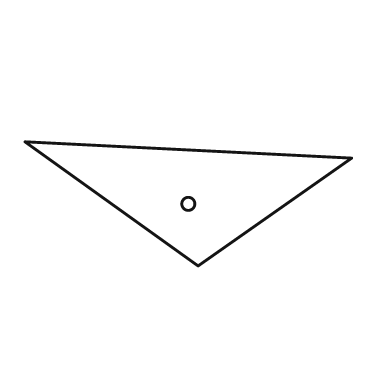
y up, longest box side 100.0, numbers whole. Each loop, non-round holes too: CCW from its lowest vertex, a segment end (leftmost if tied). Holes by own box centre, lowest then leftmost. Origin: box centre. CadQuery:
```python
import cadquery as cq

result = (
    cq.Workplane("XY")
    .moveTo(3.0, -19.0)
    .lineTo(50.0, 14.0)
    .lineTo(-50.0, 19.0)
    .close()
    .moveTo(0.0, 0.0)
    .circle(2.0)
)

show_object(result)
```